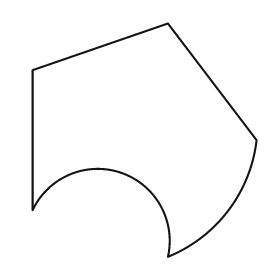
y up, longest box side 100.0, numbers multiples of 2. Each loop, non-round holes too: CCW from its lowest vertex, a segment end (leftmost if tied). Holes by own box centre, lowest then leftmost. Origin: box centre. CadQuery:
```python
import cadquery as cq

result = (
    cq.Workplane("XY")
    .moveTo(10.0, -50.0)
    .threePointArc((36.0, -30.0), (48.0, 0.0))
    .lineTo(10.0, 50.0)
    .lineTo(-48.0, 30.0)
    .lineTo(-48.0, -30.0)
    .threePointArc((-10.0, -14.0), (10.0, -50.0))
    .close()
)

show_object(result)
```